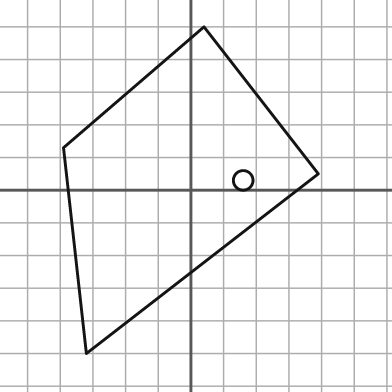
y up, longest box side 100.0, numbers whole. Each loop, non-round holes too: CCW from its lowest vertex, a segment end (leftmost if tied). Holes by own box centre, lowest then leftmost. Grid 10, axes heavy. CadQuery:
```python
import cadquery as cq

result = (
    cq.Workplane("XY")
    .moveTo(-32.0, -50.0)
    .lineTo(39.0, 5.0)
    .lineTo(4.0, 50.0)
    .lineTo(-39.0, 13.0)
    .close()
    .moveTo(16.0, 3.0)
    .circle(3.0)
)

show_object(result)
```